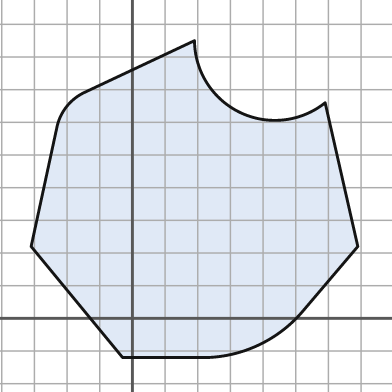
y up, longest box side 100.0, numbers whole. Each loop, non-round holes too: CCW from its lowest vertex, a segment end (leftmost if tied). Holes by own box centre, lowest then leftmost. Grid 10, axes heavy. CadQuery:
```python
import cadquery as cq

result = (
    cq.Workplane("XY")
    .moveTo(-3.0, -12.0)
    .lineTo(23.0, -12.0)
    .threePointArc((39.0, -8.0), (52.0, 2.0))
    .lineTo(69.0, 22.0)
    .lineTo(59.0, 66.0)
    .threePointArc((33.0, 63.0), (19.0, 85.0))
    .lineTo(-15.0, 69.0)
    .threePointArc((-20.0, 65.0), (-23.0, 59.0))
    .lineTo(-31.0, 22.0)
    .close()
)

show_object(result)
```